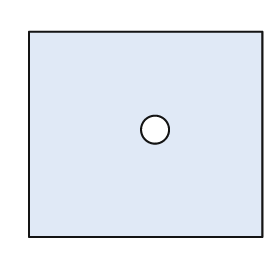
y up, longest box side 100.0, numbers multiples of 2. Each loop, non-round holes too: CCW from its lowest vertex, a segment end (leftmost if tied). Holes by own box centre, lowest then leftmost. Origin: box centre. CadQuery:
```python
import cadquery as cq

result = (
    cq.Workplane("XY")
    .moveTo(-50.0, -44.0)
    .lineTo(50.0, -44.0)
    .lineTo(50.0, 44.0)
    .lineTo(-50.0, 44.0)
    .close()
    .moveTo(4.0, 2.0)
    .circle(6.0)
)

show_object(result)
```